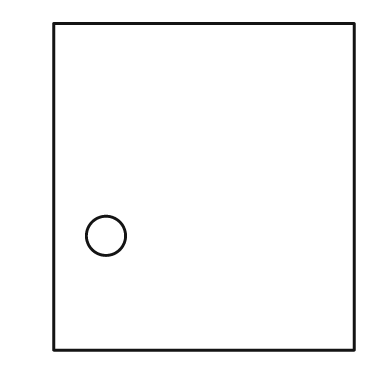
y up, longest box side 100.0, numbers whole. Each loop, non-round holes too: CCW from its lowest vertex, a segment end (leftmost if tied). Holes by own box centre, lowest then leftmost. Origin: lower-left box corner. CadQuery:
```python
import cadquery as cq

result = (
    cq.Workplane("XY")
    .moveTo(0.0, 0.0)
    .lineTo(92.0, 0.0)
    .lineTo(92.0, 100.0)
    .lineTo(0.0, 100.0)
    .close()
    .moveTo(16.0, 35.0)
    .circle(6.0)
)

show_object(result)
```